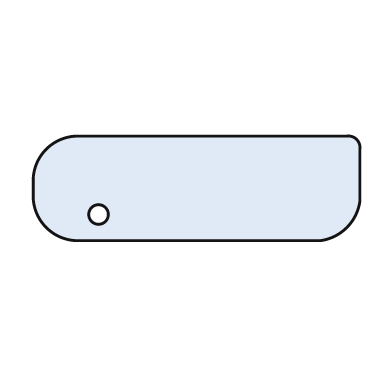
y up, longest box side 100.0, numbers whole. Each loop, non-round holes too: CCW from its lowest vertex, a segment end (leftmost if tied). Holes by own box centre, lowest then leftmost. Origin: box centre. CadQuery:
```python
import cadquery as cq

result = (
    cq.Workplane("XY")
    .moveTo(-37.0, -16.0)
    .lineTo(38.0, -16.0)
    .threePointArc((46.0, -12.0), (50.0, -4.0))
    .lineTo(50.0, 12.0)
    .threePointArc((49.0, 15.0), (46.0, 16.0))
    .lineTo(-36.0, 16.0)
    .threePointArc((-46.0, 12.0), (-50.0, 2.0))
    .lineTo(-50.0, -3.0)
    .threePointArc((-46.0, -12.0), (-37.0, -16.0))
    .close()
    .moveTo(-30.0, -8.0)
    .circle(3.0)
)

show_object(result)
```